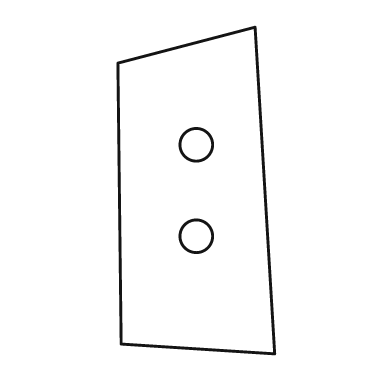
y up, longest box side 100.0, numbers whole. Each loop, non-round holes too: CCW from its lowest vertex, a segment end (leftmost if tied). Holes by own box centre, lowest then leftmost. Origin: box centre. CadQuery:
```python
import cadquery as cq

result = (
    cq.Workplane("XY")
    .moveTo(24.0, -50.0)
    .lineTo(18.0, 50.0)
    .lineTo(-24.0, 39.0)
    .lineTo(-23.0, -47.0)
    .close()
    .moveTo(0.0, -14.0)
    .circle(5.0)
    .moveTo(0.0, 14.0)
    .circle(5.0)
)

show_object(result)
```